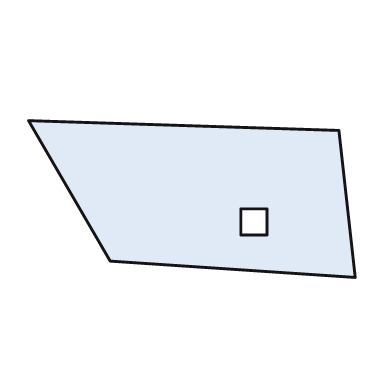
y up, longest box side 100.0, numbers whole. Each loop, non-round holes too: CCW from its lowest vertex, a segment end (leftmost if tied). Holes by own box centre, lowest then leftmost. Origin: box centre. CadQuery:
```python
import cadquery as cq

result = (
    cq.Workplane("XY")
    .moveTo(50.0, -24.0)
    .lineTo(45.0, 21.0)
    .lineTo(-50.0, 24.0)
    .lineTo(-25.0, -19.0)
    .close()
    .moveTo(15.0, -11.0)
    .lineTo(23.0, -11.0)
    .lineTo(23.0, -3.0)
    .lineTo(15.0, -3.0)
    .close()
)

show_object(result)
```